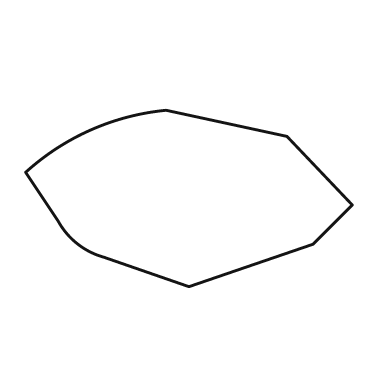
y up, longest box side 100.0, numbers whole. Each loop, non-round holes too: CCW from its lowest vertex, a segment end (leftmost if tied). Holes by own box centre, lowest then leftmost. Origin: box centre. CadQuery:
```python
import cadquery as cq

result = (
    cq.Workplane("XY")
    .moveTo(0.0, -27.0)
    .lineTo(38.0, -14.0)
    .lineTo(50.0, -2.0)
    .lineTo(30.0, 19.0)
    .lineTo(-7.0, 27.0)
    .threePointArc((-30.0, 21.0), (-50.0, 8.0))
    .lineTo(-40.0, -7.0)
    .threePointArc((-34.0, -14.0), (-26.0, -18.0))
    .close()
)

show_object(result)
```